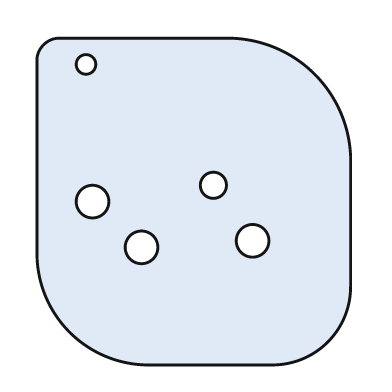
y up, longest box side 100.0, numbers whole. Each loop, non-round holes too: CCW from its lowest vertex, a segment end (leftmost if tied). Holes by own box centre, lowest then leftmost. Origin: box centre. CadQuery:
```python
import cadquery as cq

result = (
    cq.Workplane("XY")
    .moveTo(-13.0, -50.0)
    .lineTo(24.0, -50.0)
    .threePointArc((41.0, -43.0), (48.0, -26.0))
    .lineTo(48.0, 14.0)
    .threePointArc((37.0, 39.0), (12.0, 50.0))
    .lineTo(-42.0, 50.0)
    .threePointArc((-46.0, 48.0), (-48.0, 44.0))
    .lineTo(-48.0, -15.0)
    .threePointArc((-38.0, -40.0), (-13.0, -50.0))
    .close()
    .moveTo(-16.0, -14.0)
    .circle(5.0)
    .moveTo(18.0, -12.0)
    .circle(5.0)
    .moveTo(-31.0, 0.0)
    .circle(5.0)
    .moveTo(6.0, 5.0)
    .circle(4.0)
    .moveTo(-33.0, 42.0)
    .circle(3.0)
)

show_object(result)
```